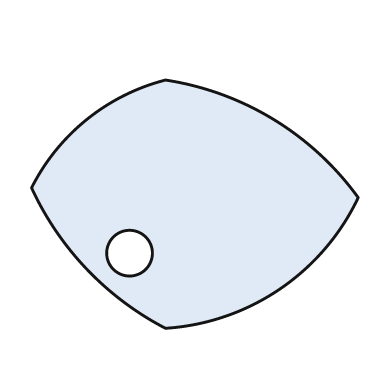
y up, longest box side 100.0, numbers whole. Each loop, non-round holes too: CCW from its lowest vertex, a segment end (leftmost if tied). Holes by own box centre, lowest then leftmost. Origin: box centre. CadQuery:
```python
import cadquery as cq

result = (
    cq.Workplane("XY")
    .moveTo(-9.0, -38.0)
    .threePointArc((26.0, -26.0), (50.0, 2.0))
    .threePointArc((24.0, 26.0), (-9.0, 38.0))
    .threePointArc((-33.0, 26.0), (-50.0, 5.0))
    .threePointArc((-33.0, -20.0), (-9.0, -38.0))
    .close()
    .moveTo(-20.0, -15.0)
    .circle(7.0)
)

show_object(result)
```